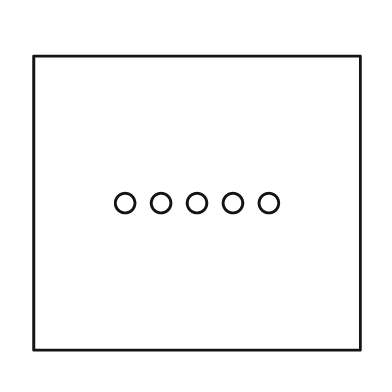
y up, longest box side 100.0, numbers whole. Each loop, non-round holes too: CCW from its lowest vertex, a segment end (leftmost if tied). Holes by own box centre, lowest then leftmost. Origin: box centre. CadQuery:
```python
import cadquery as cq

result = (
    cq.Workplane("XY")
    .moveTo(-50.0, -45.0)
    .lineTo(50.0, -45.0)
    .lineTo(50.0, 45.0)
    .lineTo(-50.0, 45.0)
    .close()
    .moveTo(-22.0, 0.0)
    .circle(3.0)
    .moveTo(-11.0, 0.0)
    .circle(3.0)
    .moveTo(0.0, 0.0)
    .circle(3.0)
    .moveTo(11.0, 0.0)
    .circle(3.0)
    .moveTo(22.0, 0.0)
    .circle(3.0)
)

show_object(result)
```